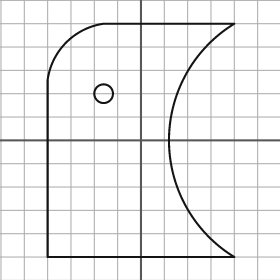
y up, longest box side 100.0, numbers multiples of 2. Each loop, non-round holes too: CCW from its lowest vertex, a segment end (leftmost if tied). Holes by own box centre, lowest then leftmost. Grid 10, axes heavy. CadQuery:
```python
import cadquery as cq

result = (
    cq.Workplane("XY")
    .moveTo(-40.0, -50.0)
    .lineTo(40.0, -50.0)
    .threePointArc((12.0, 0.0), (40.0, 50.0))
    .lineTo(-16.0, 50.0)
    .threePointArc((-32.0, 42.0), (-40.0, 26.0))
    .close()
    .moveTo(-16.0, 20.0)
    .circle(4.0)
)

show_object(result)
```